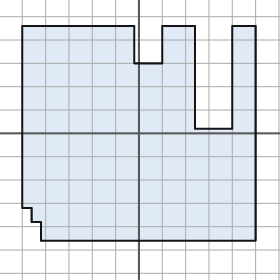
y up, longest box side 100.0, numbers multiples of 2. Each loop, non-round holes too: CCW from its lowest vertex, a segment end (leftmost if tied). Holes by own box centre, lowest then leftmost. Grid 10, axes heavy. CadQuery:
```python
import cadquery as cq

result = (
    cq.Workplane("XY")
    .moveTo(-42.0, -46.0)
    .lineTo(50.0, -46.0)
    .lineTo(50.0, 46.0)
    .lineTo(40.0, 46.0)
    .lineTo(40.0, 2.0)
    .lineTo(24.0, 2.0)
    .lineTo(24.0, 46.0)
    .lineTo(10.0, 46.0)
    .lineTo(10.0, 30.0)
    .lineTo(-2.0, 30.0)
    .lineTo(-2.0, 46.0)
    .lineTo(-50.0, 46.0)
    .lineTo(-50.0, -32.0)
    .lineTo(-46.0, -32.0)
    .lineTo(-46.0, -38.0)
    .lineTo(-42.0, -38.0)
    .close()
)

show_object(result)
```